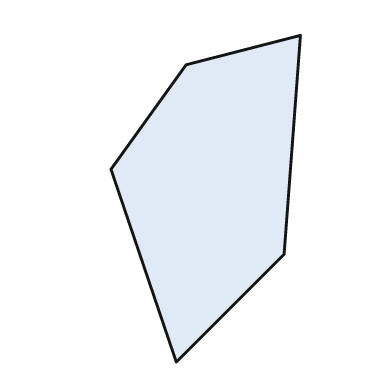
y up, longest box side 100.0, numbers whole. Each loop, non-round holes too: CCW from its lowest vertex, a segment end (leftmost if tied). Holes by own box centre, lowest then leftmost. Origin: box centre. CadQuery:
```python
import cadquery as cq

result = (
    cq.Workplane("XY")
    .moveTo(-9.0, -50.0)
    .lineTo(24.0, -17.0)
    .lineTo(29.0, 50.0)
    .lineTo(-6.0, 41.0)
    .lineTo(-29.0, 9.0)
    .close()
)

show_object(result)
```